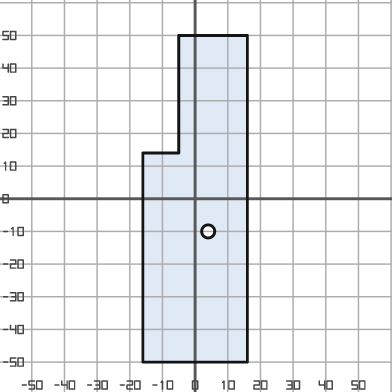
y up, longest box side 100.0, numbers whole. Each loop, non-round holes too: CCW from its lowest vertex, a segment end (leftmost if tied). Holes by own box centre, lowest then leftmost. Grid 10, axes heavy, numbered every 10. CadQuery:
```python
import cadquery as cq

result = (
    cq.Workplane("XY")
    .moveTo(-16.0, -50.0)
    .lineTo(16.0, -50.0)
    .lineTo(16.0, 50.0)
    .lineTo(-5.0, 50.0)
    .lineTo(-5.0, 14.0)
    .lineTo(-16.0, 14.0)
    .close()
    .moveTo(4.0, -10.0)
    .circle(2.0)
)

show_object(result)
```